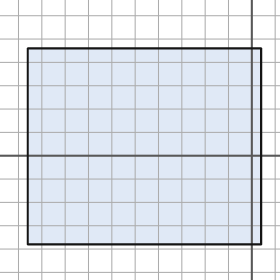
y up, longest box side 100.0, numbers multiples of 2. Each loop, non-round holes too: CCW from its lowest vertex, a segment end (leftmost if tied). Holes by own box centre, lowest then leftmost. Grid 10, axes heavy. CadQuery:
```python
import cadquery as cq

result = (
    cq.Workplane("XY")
    .moveTo(-96.0, -38.0)
    .lineTo(4.0, -38.0)
    .lineTo(4.0, 46.0)
    .lineTo(-96.0, 46.0)
    .close()
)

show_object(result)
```